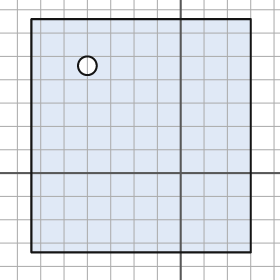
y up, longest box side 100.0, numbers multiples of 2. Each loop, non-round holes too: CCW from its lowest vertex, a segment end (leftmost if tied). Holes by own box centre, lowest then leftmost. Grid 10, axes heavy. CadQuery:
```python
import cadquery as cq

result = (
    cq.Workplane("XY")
    .moveTo(-64.0, -34.0)
    .lineTo(30.0, -34.0)
    .lineTo(30.0, 66.0)
    .lineTo(-64.0, 66.0)
    .close()
    .moveTo(-40.0, 46.0)
    .circle(4.0)
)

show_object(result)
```